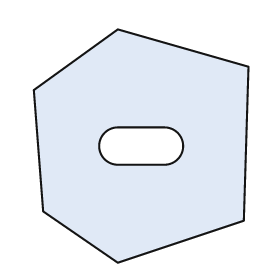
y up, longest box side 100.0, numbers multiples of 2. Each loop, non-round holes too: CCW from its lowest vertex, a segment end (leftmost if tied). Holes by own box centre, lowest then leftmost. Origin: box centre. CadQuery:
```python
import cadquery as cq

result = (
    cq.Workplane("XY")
    .moveTo(-10.0, -50.0)
    .lineTo(44.0, -32.0)
    .lineTo(46.0, 34.0)
    .lineTo(-10.0, 50.0)
    .lineTo(-46.0, 24.0)
    .lineTo(-42.0, -28.0)
    .close()
    .moveTo(-10.0, -8.0)
    .lineTo(10.0, -8.0)
    .threePointArc((18.0, 0.0), (10.0, 8.0))
    .lineTo(-10.0, 8.0)
    .threePointArc((-18.0, 0.0), (-10.0, -8.0))
    .close()
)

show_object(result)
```